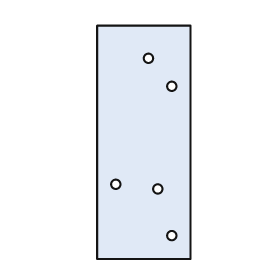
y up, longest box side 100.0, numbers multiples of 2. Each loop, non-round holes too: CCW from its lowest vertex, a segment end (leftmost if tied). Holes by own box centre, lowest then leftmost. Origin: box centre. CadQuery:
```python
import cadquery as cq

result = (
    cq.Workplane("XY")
    .moveTo(-20.0, -50.0)
    .lineTo(20.0, -50.0)
    .lineTo(20.0, 50.0)
    .lineTo(-20.0, 50.0)
    .close()
    .moveTo(12.0, -40.0)
    .circle(2.0)
    .moveTo(6.0, -20.0)
    .circle(2.0)
    .moveTo(-12.0, -18.0)
    .circle(2.0)
    .moveTo(12.0, 24.0)
    .circle(2.0)
    .moveTo(2.0, 36.0)
    .circle(2.0)
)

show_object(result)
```